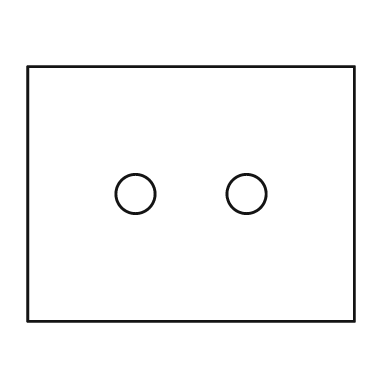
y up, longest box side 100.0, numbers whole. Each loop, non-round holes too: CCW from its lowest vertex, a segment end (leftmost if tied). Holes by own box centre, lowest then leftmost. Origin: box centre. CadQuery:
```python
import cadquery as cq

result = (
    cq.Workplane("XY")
    .moveTo(-50.0, -39.0)
    .lineTo(50.0, -39.0)
    .lineTo(50.0, 39.0)
    .lineTo(-50.0, 39.0)
    .close()
    .moveTo(-17.0, 0.0)
    .circle(6.0)
    .moveTo(17.0, 0.0)
    .circle(6.0)
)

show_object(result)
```